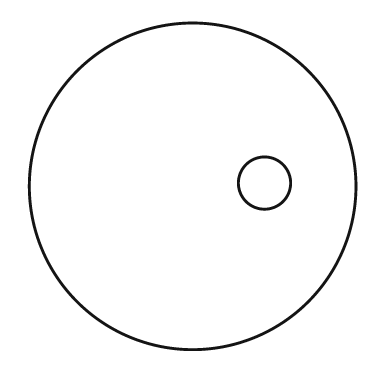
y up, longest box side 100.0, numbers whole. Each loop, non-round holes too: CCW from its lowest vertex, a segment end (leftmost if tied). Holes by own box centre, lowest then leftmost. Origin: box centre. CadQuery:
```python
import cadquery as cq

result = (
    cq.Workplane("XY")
    .moveTo(0.0, 0.0)
    .circle(50.0)
    .moveTo(22.0, 1.0)
    .circle(8.0)
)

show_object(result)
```